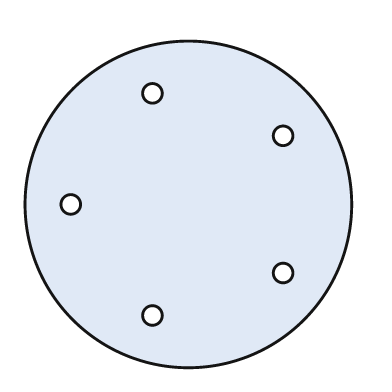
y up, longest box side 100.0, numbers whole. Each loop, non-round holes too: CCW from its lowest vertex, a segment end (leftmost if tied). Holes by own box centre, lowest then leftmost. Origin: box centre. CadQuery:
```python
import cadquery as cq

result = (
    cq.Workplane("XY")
    .moveTo(0.0, 0.0)
    .circle(50.0)
    .moveTo(-11.0, -34.0)
    .circle(3.0)
    .moveTo(29.0, -21.0)
    .circle(3.0)
    .moveTo(-36.0, 0.0)
    .circle(3.0)
    .moveTo(29.0, 21.0)
    .circle(3.0)
    .moveTo(-11.0, 34.0)
    .circle(3.0)
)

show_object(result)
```